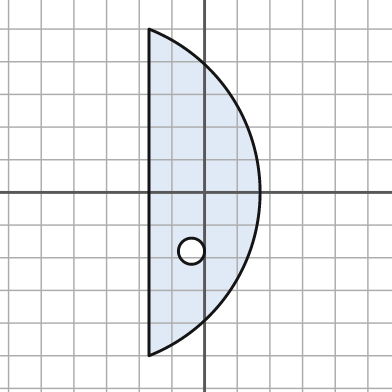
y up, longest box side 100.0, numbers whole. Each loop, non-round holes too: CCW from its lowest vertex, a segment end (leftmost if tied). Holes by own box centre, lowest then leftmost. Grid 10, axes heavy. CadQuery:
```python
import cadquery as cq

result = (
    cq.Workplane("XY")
    .moveTo(-17.0, -50.0)
    .threePointArc((17.0, 0.0), (-17.0, 50.0))
    .close()
    .moveTo(-4.0, -18.0)
    .circle(4.0)
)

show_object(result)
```